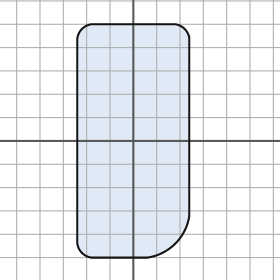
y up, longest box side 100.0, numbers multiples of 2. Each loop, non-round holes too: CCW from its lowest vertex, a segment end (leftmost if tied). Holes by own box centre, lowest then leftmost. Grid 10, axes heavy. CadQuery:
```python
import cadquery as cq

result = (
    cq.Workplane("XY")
    .moveTo(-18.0, -50.0)
    .lineTo(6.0, -50.0)
    .threePointArc((18.0, -44.0), (24.0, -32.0))
    .lineTo(24.0, 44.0)
    .threePointArc((22.0, 48.0), (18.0, 50.0))
    .lineTo(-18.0, 50.0)
    .threePointArc((-22.0, 48.0), (-24.0, 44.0))
    .lineTo(-24.0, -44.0)
    .threePointArc((-22.0, -48.0), (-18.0, -50.0))
    .close()
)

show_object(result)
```